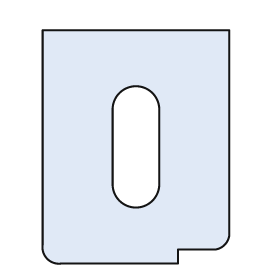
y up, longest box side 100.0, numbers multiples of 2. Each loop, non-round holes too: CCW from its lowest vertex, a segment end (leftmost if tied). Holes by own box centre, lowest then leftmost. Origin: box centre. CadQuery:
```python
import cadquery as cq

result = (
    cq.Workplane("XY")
    .moveTo(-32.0, -50.0)
    .lineTo(18.0, -50.0)
    .lineTo(18.0, -44.0)
    .lineTo(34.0, -44.0)
    .threePointArc((38.0, -42.0), (40.0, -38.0))
    .lineTo(40.0, 50.0)
    .lineTo(-40.0, 50.0)
    .lineTo(-40.0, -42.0)
    .threePointArc((-38.0, -48.0), (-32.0, -50.0))
    .close()
    .moveTo(-10.0, -16.0)
    .threePointArc((0.0, -26.0), (10.0, -16.0))
    .lineTo(10.0, 16.0)
    .threePointArc((0.0, 26.0), (-10.0, 16.0))
    .close()
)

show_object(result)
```